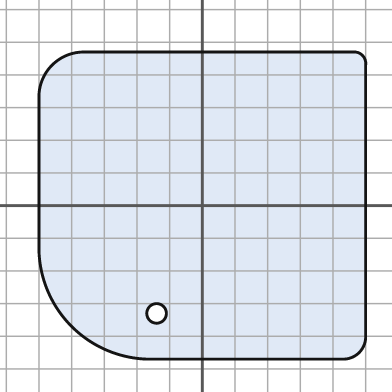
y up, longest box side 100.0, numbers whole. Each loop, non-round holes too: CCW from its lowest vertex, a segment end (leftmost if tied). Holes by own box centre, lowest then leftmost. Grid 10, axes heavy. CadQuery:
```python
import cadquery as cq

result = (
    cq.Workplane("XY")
    .moveTo(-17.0, -47.0)
    .lineTo(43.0, -47.0)
    .threePointArc((48.0, -45.0), (50.0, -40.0))
    .lineTo(50.0, 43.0)
    .threePointArc((49.0, 46.0), (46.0, 47.0))
    .lineTo(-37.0, 47.0)
    .threePointArc((-46.0, 43.0), (-50.0, 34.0))
    .lineTo(-50.0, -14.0)
    .threePointArc((-40.0, -37.0), (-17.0, -47.0))
    .close()
    .moveTo(-14.0, -33.0)
    .circle(3.0)
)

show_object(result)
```